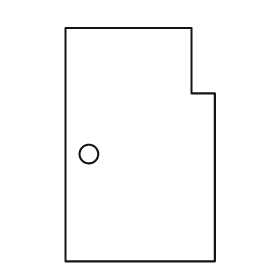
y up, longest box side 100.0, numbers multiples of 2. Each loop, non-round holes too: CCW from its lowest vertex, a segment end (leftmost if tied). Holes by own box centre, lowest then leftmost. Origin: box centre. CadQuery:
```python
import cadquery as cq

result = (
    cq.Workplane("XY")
    .moveTo(-32.0, -50.0)
    .lineTo(32.0, -50.0)
    .lineTo(32.0, 22.0)
    .lineTo(22.0, 22.0)
    .lineTo(22.0, 50.0)
    .lineTo(-32.0, 50.0)
    .close()
    .moveTo(-22.0, -4.0)
    .circle(4.0)
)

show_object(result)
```